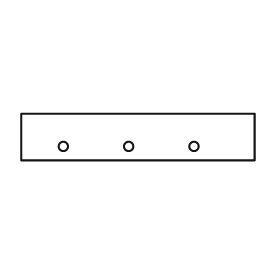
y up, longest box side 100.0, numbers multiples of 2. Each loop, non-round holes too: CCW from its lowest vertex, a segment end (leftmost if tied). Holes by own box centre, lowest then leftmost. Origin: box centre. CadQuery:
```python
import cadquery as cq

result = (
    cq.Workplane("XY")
    .moveTo(-50.0, -10.0)
    .lineTo(50.0, -10.0)
    .lineTo(50.0, 10.0)
    .lineTo(-50.0, 10.0)
    .close()
    .moveTo(-32.0, -4.0)
    .circle(2.0)
    .moveTo(-4.0, -4.0)
    .circle(2.0)
    .moveTo(24.0, -4.0)
    .circle(2.0)
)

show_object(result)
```